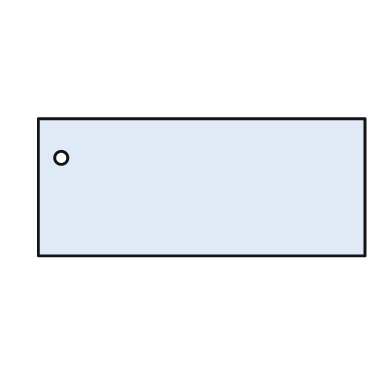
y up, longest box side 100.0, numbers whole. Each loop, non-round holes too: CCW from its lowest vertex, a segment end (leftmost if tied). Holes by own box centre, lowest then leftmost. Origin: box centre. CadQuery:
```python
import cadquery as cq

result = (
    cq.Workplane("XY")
    .moveTo(-50.0, -21.0)
    .lineTo(50.0, -21.0)
    .lineTo(50.0, 21.0)
    .lineTo(-50.0, 21.0)
    .close()
    .moveTo(-43.0, 9.0)
    .circle(2.0)
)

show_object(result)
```